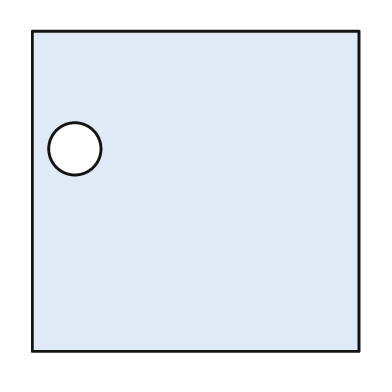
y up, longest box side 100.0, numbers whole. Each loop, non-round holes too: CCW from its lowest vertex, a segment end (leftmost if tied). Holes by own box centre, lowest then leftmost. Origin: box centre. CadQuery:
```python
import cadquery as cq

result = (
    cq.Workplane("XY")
    .moveTo(-50.0, -49.0)
    .lineTo(50.0, -49.0)
    .lineTo(50.0, 49.0)
    .lineTo(-50.0, 49.0)
    .close()
    .moveTo(-37.0, 13.0)
    .circle(8.0)
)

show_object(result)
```